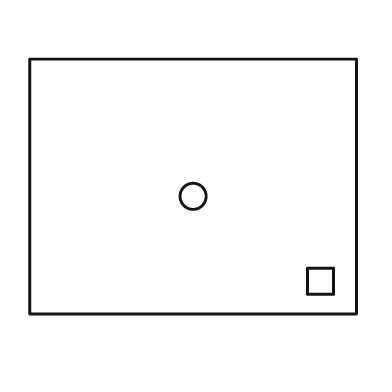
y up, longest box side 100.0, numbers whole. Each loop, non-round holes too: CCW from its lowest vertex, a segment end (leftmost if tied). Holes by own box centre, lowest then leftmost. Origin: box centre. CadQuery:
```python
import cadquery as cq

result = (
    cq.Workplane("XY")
    .moveTo(-50.0, -39.0)
    .lineTo(50.0, -39.0)
    .lineTo(50.0, 39.0)
    .lineTo(-50.0, 39.0)
    .close()
    .moveTo(35.0, -33.0)
    .lineTo(43.0, -33.0)
    .lineTo(43.0, -25.0)
    .lineTo(35.0, -25.0)
    .close()
    .moveTo(0.0, -3.0)
    .circle(4.0)
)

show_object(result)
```